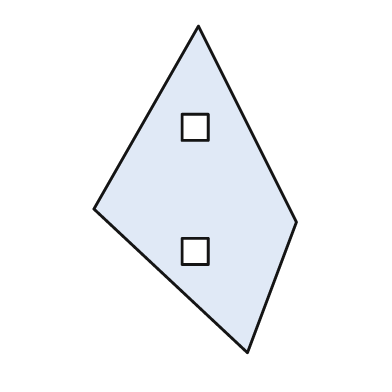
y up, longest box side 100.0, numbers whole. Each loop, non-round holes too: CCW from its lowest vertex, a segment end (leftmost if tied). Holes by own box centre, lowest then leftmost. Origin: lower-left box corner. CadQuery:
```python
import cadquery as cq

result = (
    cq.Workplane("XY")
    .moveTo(47.0, 0.0)
    .lineTo(62.0, 40.0)
    .lineTo(32.0, 100.0)
    .lineTo(0.0, 44.0)
    .close()
    .moveTo(27.0, 27.0)
    .lineTo(35.0, 27.0)
    .lineTo(35.0, 35.0)
    .lineTo(27.0, 35.0)
    .close()
    .moveTo(27.0, 65.0)
    .lineTo(35.0, 65.0)
    .lineTo(35.0, 73.0)
    .lineTo(27.0, 73.0)
    .close()
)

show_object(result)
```